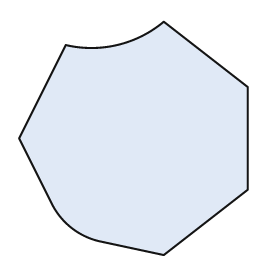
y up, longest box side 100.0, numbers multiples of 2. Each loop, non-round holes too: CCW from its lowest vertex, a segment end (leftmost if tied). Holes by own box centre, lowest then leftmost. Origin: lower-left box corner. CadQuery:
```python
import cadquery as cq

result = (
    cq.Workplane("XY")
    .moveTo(62.0, 0.0)
    .lineTo(98.0, 28.0)
    .lineTo(98.0, 72.0)
    .lineTo(62.0, 100.0)
    .threePointArc((42.0, 90.0), (20.0, 90.0))
    .lineTo(0.0, 50.0)
    .lineTo(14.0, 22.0)
    .threePointArc((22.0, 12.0), (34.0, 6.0))
    .close()
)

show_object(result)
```